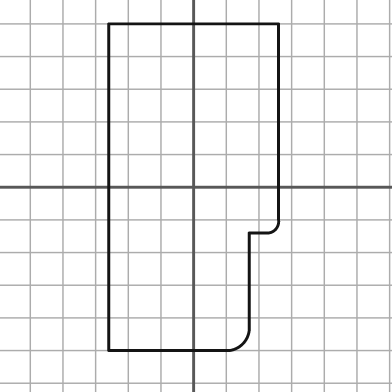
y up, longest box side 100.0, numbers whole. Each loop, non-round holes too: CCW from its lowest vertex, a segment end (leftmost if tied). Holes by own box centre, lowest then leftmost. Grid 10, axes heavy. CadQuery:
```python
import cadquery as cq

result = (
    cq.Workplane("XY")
    .moveTo(-26.0, -50.0)
    .lineTo(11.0, -50.0)
    .threePointArc((15.0, -48.0), (17.0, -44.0))
    .lineTo(17.0, -14.0)
    .lineTo(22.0, -14.0)
    .threePointArc((25.0, -13.0), (26.0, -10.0))
    .lineTo(26.0, 50.0)
    .lineTo(-26.0, 50.0)
    .close()
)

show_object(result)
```